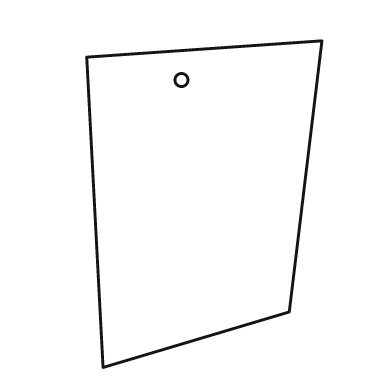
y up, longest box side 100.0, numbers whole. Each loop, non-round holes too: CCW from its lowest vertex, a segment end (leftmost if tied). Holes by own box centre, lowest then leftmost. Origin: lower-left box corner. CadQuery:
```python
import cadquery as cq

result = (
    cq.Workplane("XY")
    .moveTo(5.0, 0.0)
    .lineTo(62.0, 17.0)
    .lineTo(72.0, 100.0)
    .lineTo(0.0, 95.0)
    .close()
    .moveTo(29.0, 88.0)
    .circle(2.0)
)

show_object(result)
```